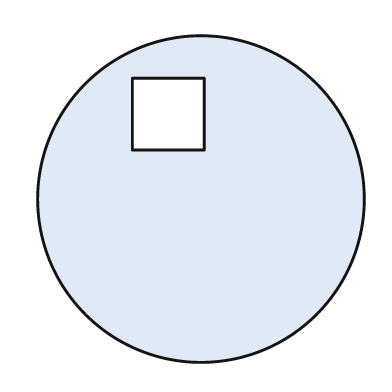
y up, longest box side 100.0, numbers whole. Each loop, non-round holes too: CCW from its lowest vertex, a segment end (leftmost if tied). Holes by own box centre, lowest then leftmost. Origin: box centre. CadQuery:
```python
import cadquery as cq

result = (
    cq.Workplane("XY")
    .moveTo(0.0, 0.0)
    .circle(50.0)
    .moveTo(-21.0, 15.0)
    .lineTo(1.0, 15.0)
    .lineTo(1.0, 37.0)
    .lineTo(-21.0, 37.0)
    .close()
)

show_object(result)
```